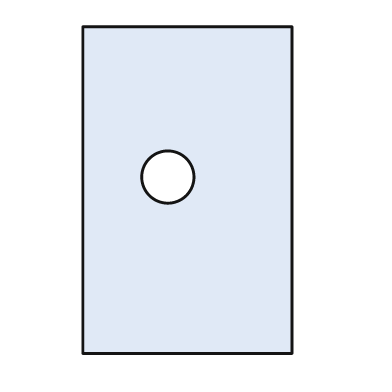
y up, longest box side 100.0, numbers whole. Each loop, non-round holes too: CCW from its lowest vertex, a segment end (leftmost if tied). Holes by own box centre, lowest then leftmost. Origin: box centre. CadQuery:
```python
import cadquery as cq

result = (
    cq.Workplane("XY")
    .moveTo(-32.0, -50.0)
    .lineTo(32.0, -50.0)
    .lineTo(32.0, 50.0)
    .lineTo(-32.0, 50.0)
    .close()
    .moveTo(-6.0, 4.0)
    .circle(8.0)
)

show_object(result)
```